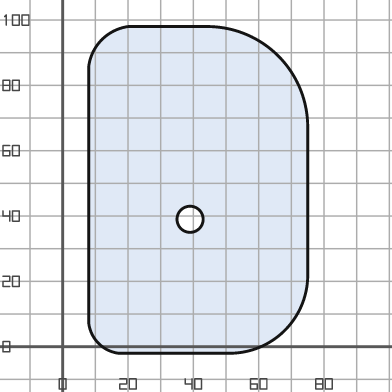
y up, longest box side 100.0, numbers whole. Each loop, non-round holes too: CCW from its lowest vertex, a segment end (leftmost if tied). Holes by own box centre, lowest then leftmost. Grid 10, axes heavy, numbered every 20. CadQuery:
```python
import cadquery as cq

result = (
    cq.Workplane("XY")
    .moveTo(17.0, -2.0)
    .lineTo(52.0, -2.0)
    .threePointArc((68.0, 5.0), (75.0, 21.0))
    .lineTo(75.0, 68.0)
    .threePointArc((66.0, 89.0), (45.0, 98.0))
    .lineTo(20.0, 98.0)
    .threePointArc((12.0, 94.0), (8.0, 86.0))
    .lineTo(8.0, 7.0)
    .threePointArc((11.0, 1.0), (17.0, -2.0))
    .close()
    .moveTo(39.0, 39.0)
    .circle(4.0)
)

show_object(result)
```